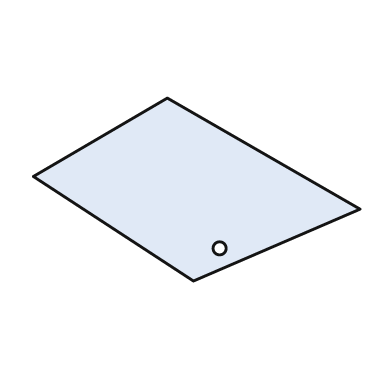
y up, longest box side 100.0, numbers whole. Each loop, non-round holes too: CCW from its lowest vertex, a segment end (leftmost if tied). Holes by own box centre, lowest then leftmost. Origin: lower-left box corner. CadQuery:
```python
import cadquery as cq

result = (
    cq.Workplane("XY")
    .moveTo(49.0, 0.0)
    .lineTo(100.0, 22.0)
    .lineTo(41.0, 56.0)
    .lineTo(0.0, 32.0)
    .close()
    .moveTo(57.0, 10.0)
    .circle(2.0)
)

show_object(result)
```